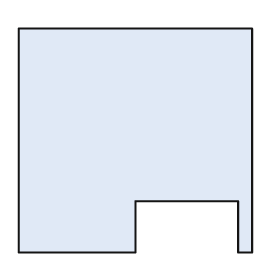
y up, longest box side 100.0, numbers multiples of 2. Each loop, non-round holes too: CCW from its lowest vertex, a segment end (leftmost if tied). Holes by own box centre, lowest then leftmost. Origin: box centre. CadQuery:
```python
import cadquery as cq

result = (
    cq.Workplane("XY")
    .moveTo(-50.0, -48.0)
    .lineTo(0.0, -48.0)
    .lineTo(0.0, -26.0)
    .lineTo(44.0, -26.0)
    .lineTo(44.0, -48.0)
    .lineTo(50.0, -48.0)
    .lineTo(50.0, 48.0)
    .lineTo(-50.0, 48.0)
    .close()
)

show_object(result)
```